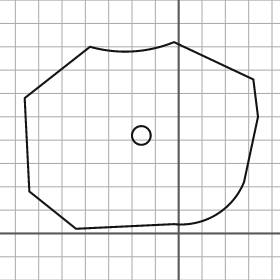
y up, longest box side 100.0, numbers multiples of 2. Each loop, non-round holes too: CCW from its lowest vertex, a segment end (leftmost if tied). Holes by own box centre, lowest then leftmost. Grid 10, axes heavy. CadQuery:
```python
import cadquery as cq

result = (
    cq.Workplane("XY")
    .moveTo(-44.0, 2.0)
    .lineTo(-2.0, 4.0)
    .threePointArc((16.0, 8.0), (28.0, 22.0))
    .lineTo(34.0, 50.0)
    .lineTo(32.0, 66.0)
    .lineTo(-2.0, 82.0)
    .threePointArc((-20.0, 78.0), (-38.0, 80.0))
    .lineTo(-66.0, 58.0)
    .lineTo(-64.0, 18.0)
    .close()
    .moveTo(-16.0, 42.0)
    .circle(4.0)
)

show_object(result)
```